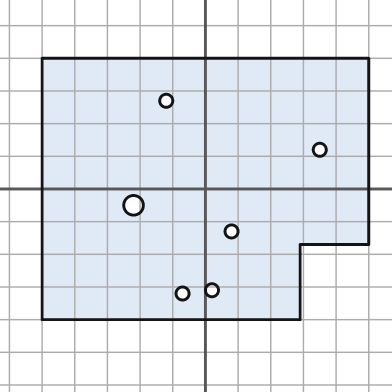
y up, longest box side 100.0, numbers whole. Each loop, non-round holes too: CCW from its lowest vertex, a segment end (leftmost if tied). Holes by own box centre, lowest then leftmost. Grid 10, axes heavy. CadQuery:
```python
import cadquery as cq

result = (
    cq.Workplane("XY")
    .moveTo(-50.0, -40.0)
    .lineTo(29.0, -40.0)
    .lineTo(29.0, -17.0)
    .lineTo(50.0, -17.0)
    .lineTo(50.0, 40.0)
    .lineTo(-50.0, 40.0)
    .close()
    .moveTo(-7.0, -32.0)
    .circle(2.0)
    .moveTo(2.0, -31.0)
    .circle(2.0)
    .moveTo(8.0, -13.0)
    .circle(2.0)
    .moveTo(-22.0, -5.0)
    .circle(3.0)
    .moveTo(35.0, 12.0)
    .circle(2.0)
    .moveTo(-12.0, 27.0)
    .circle(2.0)
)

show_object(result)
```